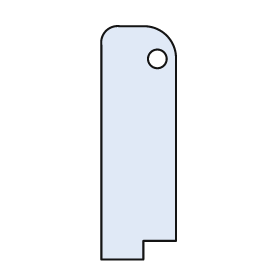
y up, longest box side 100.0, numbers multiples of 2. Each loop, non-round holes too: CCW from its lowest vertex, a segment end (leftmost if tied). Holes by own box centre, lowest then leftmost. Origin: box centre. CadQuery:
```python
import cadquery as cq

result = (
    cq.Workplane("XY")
    .moveTo(-16.0, -50.0)
    .lineTo(2.0, -50.0)
    .lineTo(2.0, -42.0)
    .lineTo(16.0, -42.0)
    .lineTo(16.0, 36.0)
    .threePointArc((12.0, 46.0), (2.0, 50.0))
    .lineTo(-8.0, 50.0)
    .threePointArc((-14.0, 48.0), (-16.0, 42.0))
    .close()
    .moveTo(8.0, 36.0)
    .circle(4.0)
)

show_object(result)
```